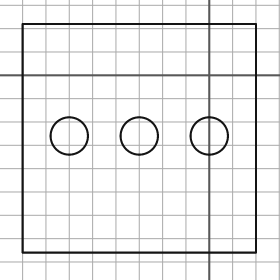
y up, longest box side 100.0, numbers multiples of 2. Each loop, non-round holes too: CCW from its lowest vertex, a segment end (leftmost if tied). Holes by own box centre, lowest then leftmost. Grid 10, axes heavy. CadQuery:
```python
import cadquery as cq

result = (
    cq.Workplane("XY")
    .moveTo(-80.0, -76.0)
    .lineTo(20.0, -76.0)
    .lineTo(20.0, 22.0)
    .lineTo(-80.0, 22.0)
    .close()
    .moveTo(-60.0, -26.0)
    .circle(8.0)
    .moveTo(-30.0, -26.0)
    .circle(8.0)
    .moveTo(0.0, -26.0)
    .circle(8.0)
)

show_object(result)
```